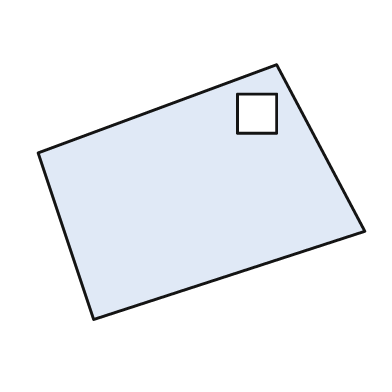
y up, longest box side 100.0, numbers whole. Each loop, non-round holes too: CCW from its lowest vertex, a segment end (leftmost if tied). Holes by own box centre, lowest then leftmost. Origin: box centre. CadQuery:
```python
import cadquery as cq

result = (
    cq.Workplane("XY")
    .moveTo(-33.0, -39.0)
    .lineTo(50.0, -12.0)
    .lineTo(23.0, 39.0)
    .lineTo(-50.0, 12.0)
    .close()
    .moveTo(11.0, 18.0)
    .lineTo(23.0, 18.0)
    .lineTo(23.0, 30.0)
    .lineTo(11.0, 30.0)
    .close()
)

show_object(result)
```